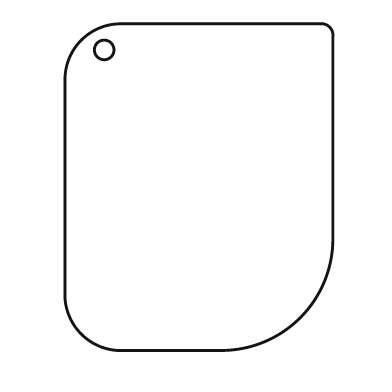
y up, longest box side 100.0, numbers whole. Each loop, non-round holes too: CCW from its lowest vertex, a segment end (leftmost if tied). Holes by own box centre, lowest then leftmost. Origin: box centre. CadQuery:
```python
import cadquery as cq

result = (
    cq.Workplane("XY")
    .moveTo(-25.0, -50.0)
    .lineTo(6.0, -50.0)
    .threePointArc((31.0, -40.0), (41.0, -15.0))
    .lineTo(41.0, 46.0)
    .threePointArc((40.0, 49.0), (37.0, 50.0))
    .lineTo(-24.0, 50.0)
    .threePointArc((-36.0, 45.0), (-41.0, 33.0))
    .lineTo(-41.0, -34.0)
    .threePointArc((-36.0, -45.0), (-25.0, -50.0))
    .close()
    .moveTo(-29.0, 42.0)
    .circle(3.0)
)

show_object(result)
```